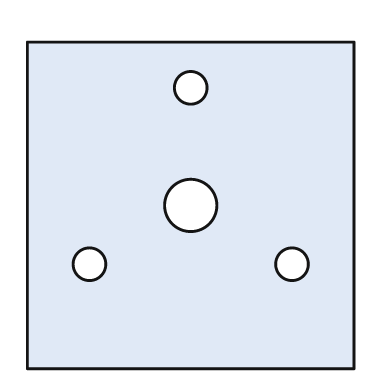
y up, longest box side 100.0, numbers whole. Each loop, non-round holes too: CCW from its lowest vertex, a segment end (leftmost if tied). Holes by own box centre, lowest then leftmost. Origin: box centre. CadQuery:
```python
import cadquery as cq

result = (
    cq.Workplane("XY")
    .moveTo(-50.0, -50.0)
    .lineTo(50.0, -50.0)
    .lineTo(50.0, 50.0)
    .lineTo(-50.0, 50.0)
    .close()
    .moveTo(-31.0, -18.0)
    .circle(5.0)
    .moveTo(31.0, -18.0)
    .circle(5.0)
    .moveTo(0.0, 0.0)
    .circle(8.0)
    .moveTo(0.0, 36.0)
    .circle(5.0)
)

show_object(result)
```